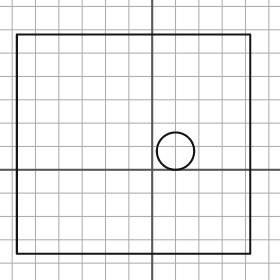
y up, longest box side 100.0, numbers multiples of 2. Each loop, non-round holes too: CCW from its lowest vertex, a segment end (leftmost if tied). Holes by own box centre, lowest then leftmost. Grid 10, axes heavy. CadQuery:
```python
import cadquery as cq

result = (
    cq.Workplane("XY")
    .moveTo(-58.0, -36.0)
    .lineTo(42.0, -36.0)
    .lineTo(42.0, 58.0)
    .lineTo(-58.0, 58.0)
    .close()
    .moveTo(10.0, 8.0)
    .circle(8.0)
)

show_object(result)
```